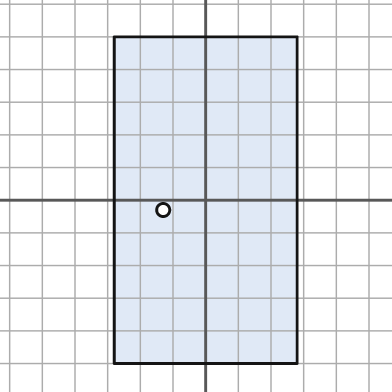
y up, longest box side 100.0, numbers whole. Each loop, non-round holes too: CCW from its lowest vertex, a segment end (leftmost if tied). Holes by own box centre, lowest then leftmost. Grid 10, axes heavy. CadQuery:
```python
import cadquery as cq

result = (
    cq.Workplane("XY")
    .moveTo(-28.0, -50.0)
    .lineTo(28.0, -50.0)
    .lineTo(28.0, 50.0)
    .lineTo(-28.0, 50.0)
    .close()
    .moveTo(-13.0, -3.0)
    .circle(2.0)
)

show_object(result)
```